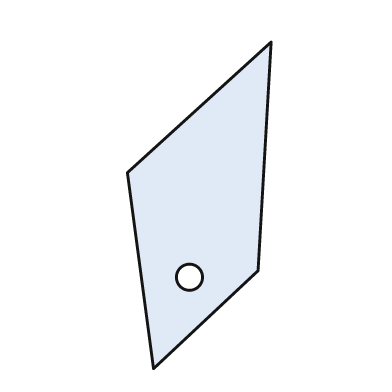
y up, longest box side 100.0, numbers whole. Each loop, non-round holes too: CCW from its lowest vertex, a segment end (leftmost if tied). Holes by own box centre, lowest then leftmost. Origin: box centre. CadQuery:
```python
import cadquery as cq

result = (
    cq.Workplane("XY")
    .moveTo(-14.0, -50.0)
    .lineTo(18.0, -20.0)
    .lineTo(22.0, 50.0)
    .lineTo(-22.0, 10.0)
    .close()
    .moveTo(-3.0, -22.0)
    .circle(4.0)
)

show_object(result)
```